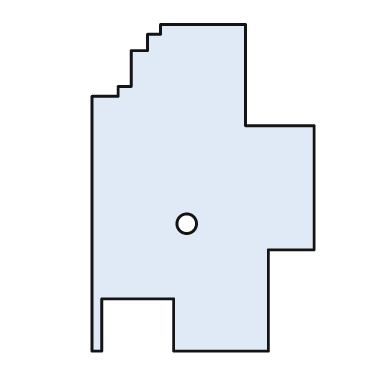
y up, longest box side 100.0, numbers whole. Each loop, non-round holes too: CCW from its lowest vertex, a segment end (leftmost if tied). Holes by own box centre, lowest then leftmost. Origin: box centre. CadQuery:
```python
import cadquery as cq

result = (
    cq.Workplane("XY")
    .moveTo(-34.0, -50.0)
    .lineTo(-31.0, -50.0)
    .lineTo(-31.0, -34.0)
    .lineTo(-9.0, -34.0)
    .lineTo(-9.0, -50.0)
    .lineTo(20.0, -50.0)
    .lineTo(20.0, -19.0)
    .lineTo(34.0, -19.0)
    .lineTo(34.0, 19.0)
    .lineTo(13.0, 19.0)
    .lineTo(13.0, 50.0)
    .lineTo(-13.0, 50.0)
    .lineTo(-13.0, 47.0)
    .lineTo(-17.0, 47.0)
    .lineTo(-17.0, 42.0)
    .lineTo(-22.0, 42.0)
    .lineTo(-22.0, 31.0)
    .lineTo(-26.0, 31.0)
    .lineTo(-26.0, 28.0)
    .lineTo(-34.0, 28.0)
    .close()
    .moveTo(-5.0, -11.0)
    .circle(3.0)
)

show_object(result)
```